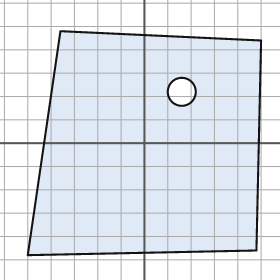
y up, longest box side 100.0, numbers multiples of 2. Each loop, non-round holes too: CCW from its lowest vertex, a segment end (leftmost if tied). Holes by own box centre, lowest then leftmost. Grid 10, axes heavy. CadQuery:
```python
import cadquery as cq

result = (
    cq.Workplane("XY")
    .moveTo(-50.0, -48.0)
    .lineTo(48.0, -46.0)
    .lineTo(50.0, 44.0)
    .lineTo(-36.0, 48.0)
    .close()
    .moveTo(16.0, 22.0)
    .circle(6.0)
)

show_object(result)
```